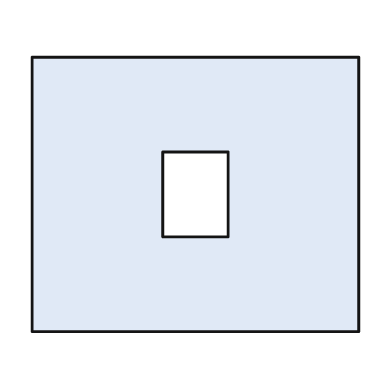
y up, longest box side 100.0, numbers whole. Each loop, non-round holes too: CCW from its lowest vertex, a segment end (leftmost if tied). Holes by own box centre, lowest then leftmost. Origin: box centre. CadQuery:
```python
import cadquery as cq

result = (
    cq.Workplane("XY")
    .moveTo(-50.0, -42.0)
    .lineTo(50.0, -42.0)
    .lineTo(50.0, 42.0)
    .lineTo(-50.0, 42.0)
    .close()
    .moveTo(-10.0, -13.0)
    .lineTo(10.0, -13.0)
    .lineTo(10.0, 13.0)
    .lineTo(-10.0, 13.0)
    .close()
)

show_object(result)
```